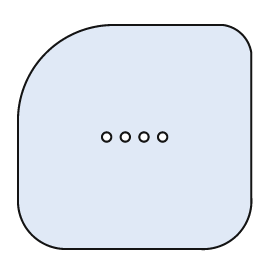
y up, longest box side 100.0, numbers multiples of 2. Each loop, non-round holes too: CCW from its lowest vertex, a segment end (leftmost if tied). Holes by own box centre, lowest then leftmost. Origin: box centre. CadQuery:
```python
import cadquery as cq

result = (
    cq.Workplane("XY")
    .moveTo(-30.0, -48.0)
    .lineTo(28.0, -48.0)
    .threePointArc((44.0, -42.0), (50.0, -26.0))
    .lineTo(50.0, 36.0)
    .threePointArc((46.0, 44.0), (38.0, 48.0))
    .lineTo(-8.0, 48.0)
    .threePointArc((-38.0, 36.0), (-50.0, 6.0))
    .lineTo(-50.0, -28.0)
    .threePointArc((-44.0, -42.0), (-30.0, -48.0))
    .close()
    .moveTo(-12.0, 0.0)
    .circle(2.0)
    .moveTo(-4.0, 0.0)
    .circle(2.0)
    .moveTo(4.0, 0.0)
    .circle(2.0)
    .moveTo(12.0, 0.0)
    .circle(2.0)
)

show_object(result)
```